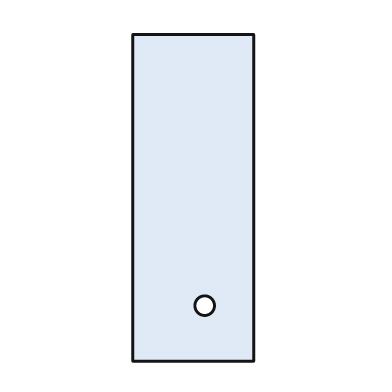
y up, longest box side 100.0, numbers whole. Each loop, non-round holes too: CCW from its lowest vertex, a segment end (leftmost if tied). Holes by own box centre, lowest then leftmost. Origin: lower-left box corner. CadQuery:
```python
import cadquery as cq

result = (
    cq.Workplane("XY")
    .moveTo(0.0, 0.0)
    .lineTo(37.0, 0.0)
    .lineTo(37.0, 100.0)
    .lineTo(0.0, 100.0)
    .close()
    .moveTo(22.0, 17.0)
    .circle(3.0)
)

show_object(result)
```